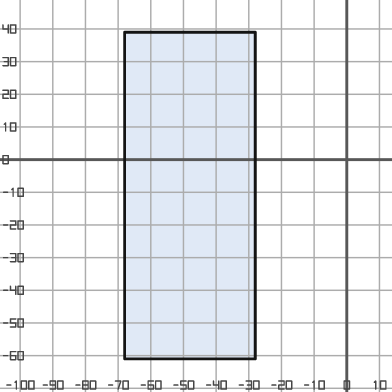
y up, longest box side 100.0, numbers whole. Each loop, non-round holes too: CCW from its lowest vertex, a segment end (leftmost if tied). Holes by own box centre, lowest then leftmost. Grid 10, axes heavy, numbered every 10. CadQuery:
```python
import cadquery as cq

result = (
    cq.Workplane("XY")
    .moveTo(-68.0, -61.0)
    .lineTo(-28.0, -61.0)
    .lineTo(-28.0, 39.0)
    .lineTo(-68.0, 39.0)
    .close()
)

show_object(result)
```